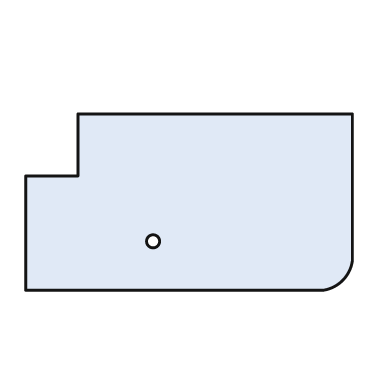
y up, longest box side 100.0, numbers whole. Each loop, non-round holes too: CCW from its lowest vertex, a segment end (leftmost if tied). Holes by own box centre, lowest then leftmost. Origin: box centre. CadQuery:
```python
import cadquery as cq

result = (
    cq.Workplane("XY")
    .moveTo(-50.0, -27.0)
    .lineTo(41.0, -27.0)
    .threePointArc((47.0, -24.0), (50.0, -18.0))
    .lineTo(50.0, 27.0)
    .lineTo(-34.0, 27.0)
    .lineTo(-34.0, 8.0)
    .lineTo(-50.0, 8.0)
    .close()
    .moveTo(-11.0, -12.0)
    .circle(2.0)
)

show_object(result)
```